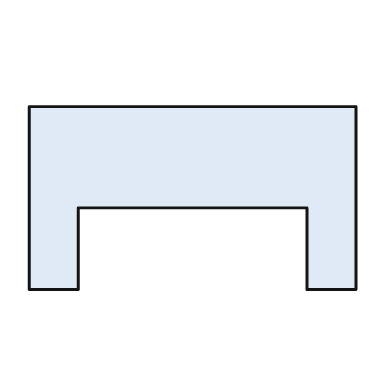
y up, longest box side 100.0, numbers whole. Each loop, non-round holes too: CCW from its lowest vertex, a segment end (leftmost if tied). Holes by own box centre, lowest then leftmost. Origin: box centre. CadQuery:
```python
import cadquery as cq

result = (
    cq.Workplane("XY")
    .moveTo(-50.0, -28.0)
    .lineTo(-35.0, -28.0)
    .lineTo(-35.0, -3.0)
    .lineTo(35.0, -3.0)
    .lineTo(35.0, -28.0)
    .lineTo(50.0, -28.0)
    .lineTo(50.0, 28.0)
    .lineTo(-50.0, 28.0)
    .close()
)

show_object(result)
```